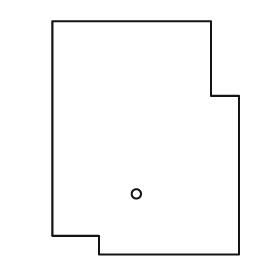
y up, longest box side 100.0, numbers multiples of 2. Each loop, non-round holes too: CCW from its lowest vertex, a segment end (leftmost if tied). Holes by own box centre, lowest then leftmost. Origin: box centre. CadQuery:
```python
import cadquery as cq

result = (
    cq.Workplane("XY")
    .moveTo(-20.0, -50.0)
    .lineTo(40.0, -50.0)
    .lineTo(40.0, 18.0)
    .lineTo(28.0, 18.0)
    .lineTo(28.0, 50.0)
    .lineTo(-40.0, 50.0)
    .lineTo(-40.0, -42.0)
    .lineTo(-20.0, -42.0)
    .close()
    .moveTo(-4.0, -24.0)
    .circle(2.0)
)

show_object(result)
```